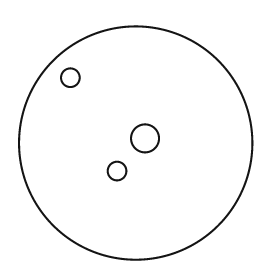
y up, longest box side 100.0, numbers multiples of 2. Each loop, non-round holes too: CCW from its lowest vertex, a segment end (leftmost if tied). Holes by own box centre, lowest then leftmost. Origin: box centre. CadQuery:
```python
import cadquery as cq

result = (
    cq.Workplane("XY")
    .moveTo(0.0, 0.0)
    .circle(50.0)
    .moveTo(-8.0, -12.0)
    .circle(4.0)
    .moveTo(4.0, 2.0)
    .circle(6.0)
    .moveTo(-28.0, 28.0)
    .circle(4.0)
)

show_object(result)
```